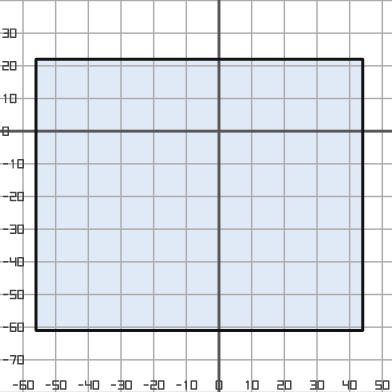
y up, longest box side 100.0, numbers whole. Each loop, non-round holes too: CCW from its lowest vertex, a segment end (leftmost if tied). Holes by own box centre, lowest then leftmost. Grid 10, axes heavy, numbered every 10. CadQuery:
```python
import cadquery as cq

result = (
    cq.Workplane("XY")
    .moveTo(-56.0, -61.0)
    .lineTo(44.0, -61.0)
    .lineTo(44.0, 22.0)
    .lineTo(-56.0, 22.0)
    .close()
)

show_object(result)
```